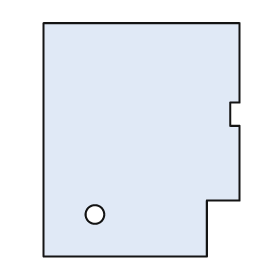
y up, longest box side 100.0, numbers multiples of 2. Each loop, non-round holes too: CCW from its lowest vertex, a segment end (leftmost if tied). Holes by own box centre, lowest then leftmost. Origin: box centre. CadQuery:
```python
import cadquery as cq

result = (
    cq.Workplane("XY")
    .moveTo(-42.0, -50.0)
    .lineTo(28.0, -50.0)
    .lineTo(28.0, -26.0)
    .lineTo(42.0, -26.0)
    .lineTo(42.0, 6.0)
    .lineTo(38.0, 6.0)
    .lineTo(38.0, 16.0)
    .lineTo(42.0, 16.0)
    .lineTo(42.0, 50.0)
    .lineTo(-42.0, 50.0)
    .close()
    .moveTo(-20.0, -32.0)
    .circle(4.0)
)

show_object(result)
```